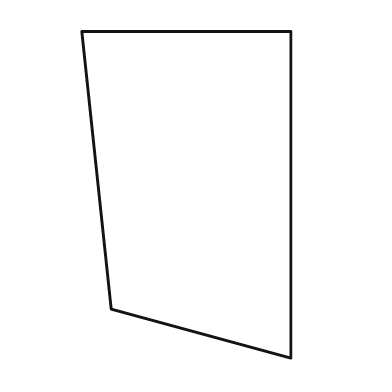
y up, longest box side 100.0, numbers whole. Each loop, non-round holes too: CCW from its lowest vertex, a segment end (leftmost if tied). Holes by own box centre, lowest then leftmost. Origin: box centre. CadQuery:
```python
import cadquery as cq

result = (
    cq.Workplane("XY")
    .moveTo(32.0, -50.0)
    .lineTo(32.0, 50.0)
    .lineTo(-32.0, 50.0)
    .lineTo(-23.0, -35.0)
    .close()
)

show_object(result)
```